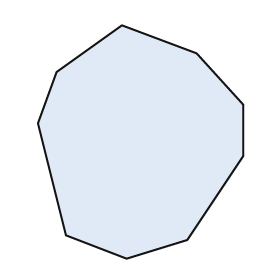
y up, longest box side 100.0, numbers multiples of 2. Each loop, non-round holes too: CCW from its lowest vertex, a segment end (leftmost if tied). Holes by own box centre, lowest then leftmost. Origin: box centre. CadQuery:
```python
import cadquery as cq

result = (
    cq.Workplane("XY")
    .moveTo(-6.0, -50.0)
    .lineTo(20.0, -42.0)
    .lineTo(44.0, -6.0)
    .lineTo(44.0, 16.0)
    .lineTo(24.0, 38.0)
    .lineTo(-8.0, 50.0)
    .lineTo(-36.0, 30.0)
    .lineTo(-44.0, 8.0)
    .lineTo(-32.0, -40.0)
    .close()
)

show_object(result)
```